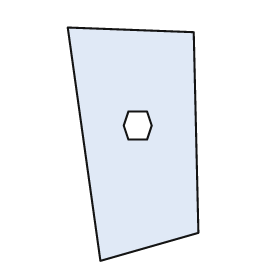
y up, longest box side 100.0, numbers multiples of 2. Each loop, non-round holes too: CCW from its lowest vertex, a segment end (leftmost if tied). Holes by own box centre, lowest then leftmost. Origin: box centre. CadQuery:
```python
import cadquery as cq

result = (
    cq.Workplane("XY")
    .moveTo(-14.0, -50.0)
    .lineTo(28.0, -38.0)
    .lineTo(26.0, 48.0)
    .lineTo(-28.0, 50.0)
    .close()
    .moveTo(-2.0, 2.0)
    .lineTo(6.0, 2.0)
    .lineTo(8.0, 8.0)
    .lineTo(6.0, 14.0)
    .lineTo(-2.0, 14.0)
    .lineTo(-4.0, 8.0)
    .close()
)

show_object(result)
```